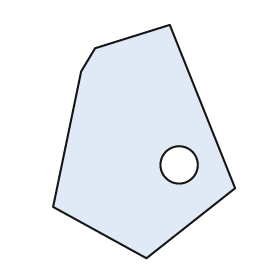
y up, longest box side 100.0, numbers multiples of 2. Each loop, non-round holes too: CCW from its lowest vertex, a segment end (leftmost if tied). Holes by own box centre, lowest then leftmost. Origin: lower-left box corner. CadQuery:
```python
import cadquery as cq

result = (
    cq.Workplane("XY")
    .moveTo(40.0, 0.0)
    .lineTo(78.0, 30.0)
    .lineTo(50.0, 100.0)
    .lineTo(18.0, 90.0)
    .lineTo(12.0, 80.0)
    .lineTo(0.0, 22.0)
    .close()
    .moveTo(54.0, 40.0)
    .circle(8.0)
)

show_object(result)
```